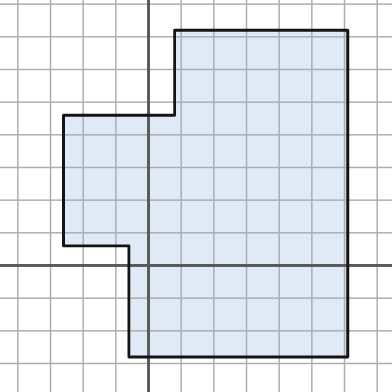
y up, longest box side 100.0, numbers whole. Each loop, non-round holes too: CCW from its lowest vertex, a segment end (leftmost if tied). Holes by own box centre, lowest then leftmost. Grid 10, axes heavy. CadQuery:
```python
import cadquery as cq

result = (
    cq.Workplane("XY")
    .moveTo(-6.0, -28.0)
    .lineTo(61.0, -28.0)
    .lineTo(61.0, 72.0)
    .lineTo(8.0, 72.0)
    .lineTo(8.0, 46.0)
    .lineTo(-26.0, 46.0)
    .lineTo(-26.0, 6.0)
    .lineTo(-6.0, 6.0)
    .close()
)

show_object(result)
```